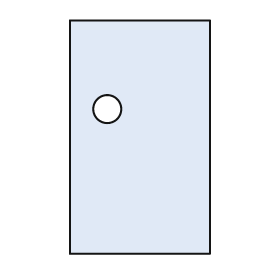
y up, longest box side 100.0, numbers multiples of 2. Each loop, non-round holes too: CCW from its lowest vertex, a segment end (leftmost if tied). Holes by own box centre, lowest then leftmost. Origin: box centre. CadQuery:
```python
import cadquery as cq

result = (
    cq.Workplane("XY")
    .moveTo(-30.0, -50.0)
    .lineTo(30.0, -50.0)
    .lineTo(30.0, 50.0)
    .lineTo(-30.0, 50.0)
    .close()
    .moveTo(-14.0, 12.0)
    .circle(6.0)
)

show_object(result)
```